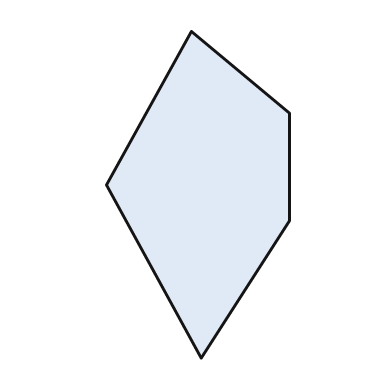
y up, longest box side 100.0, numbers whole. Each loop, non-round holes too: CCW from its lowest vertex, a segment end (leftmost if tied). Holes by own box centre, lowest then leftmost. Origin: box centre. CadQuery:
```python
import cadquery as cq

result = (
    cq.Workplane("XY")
    .moveTo(1.0, -50.0)
    .lineTo(28.0, -8.0)
    .lineTo(28.0, 25.0)
    .lineTo(-2.0, 50.0)
    .lineTo(-28.0, 3.0)
    .close()
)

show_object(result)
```